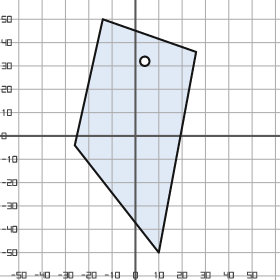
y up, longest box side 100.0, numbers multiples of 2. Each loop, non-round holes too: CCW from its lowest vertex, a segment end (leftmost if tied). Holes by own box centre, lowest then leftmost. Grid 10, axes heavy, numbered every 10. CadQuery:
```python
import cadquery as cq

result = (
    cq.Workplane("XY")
    .moveTo(10.0, -50.0)
    .lineTo(26.0, 36.0)
    .lineTo(-14.0, 50.0)
    .lineTo(-26.0, -4.0)
    .close()
    .moveTo(4.0, 32.0)
    .circle(2.0)
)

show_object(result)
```